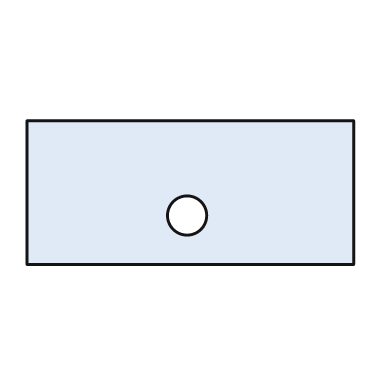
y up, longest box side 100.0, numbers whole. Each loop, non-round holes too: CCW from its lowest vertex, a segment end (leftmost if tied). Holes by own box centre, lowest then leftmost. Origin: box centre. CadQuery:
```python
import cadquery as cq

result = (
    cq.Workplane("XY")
    .moveTo(-50.0, -22.0)
    .lineTo(50.0, -22.0)
    .lineTo(50.0, 22.0)
    .lineTo(-50.0, 22.0)
    .close()
    .moveTo(-1.0, -7.0)
    .circle(6.0)
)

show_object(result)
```